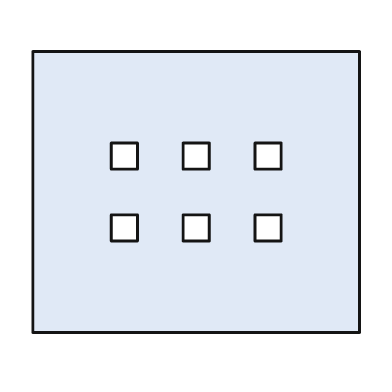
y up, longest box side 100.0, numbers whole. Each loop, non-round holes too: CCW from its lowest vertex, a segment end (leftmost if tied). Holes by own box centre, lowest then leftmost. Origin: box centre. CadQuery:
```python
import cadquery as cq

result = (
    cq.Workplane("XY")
    .moveTo(-50.0, -43.0)
    .lineTo(50.0, -43.0)
    .lineTo(50.0, 43.0)
    .lineTo(-50.0, 43.0)
    .close()
    .moveTo(-26.0, -15.0)
    .lineTo(-18.0, -15.0)
    .lineTo(-18.0, -7.0)
    .lineTo(-26.0, -7.0)
    .close()
    .moveTo(-4.0, -15.0)
    .lineTo(4.0, -15.0)
    .lineTo(4.0, -7.0)
    .lineTo(-4.0, -7.0)
    .close()
    .moveTo(18.0, -15.0)
    .lineTo(26.0, -15.0)
    .lineTo(26.0, -7.0)
    .lineTo(18.0, -7.0)
    .close()
    .moveTo(-26.0, 7.0)
    .lineTo(-18.0, 7.0)
    .lineTo(-18.0, 15.0)
    .lineTo(-26.0, 15.0)
    .close()
    .moveTo(-4.0, 7.0)
    .lineTo(4.0, 7.0)
    .lineTo(4.0, 15.0)
    .lineTo(-4.0, 15.0)
    .close()
    .moveTo(18.0, 7.0)
    .lineTo(26.0, 7.0)
    .lineTo(26.0, 15.0)
    .lineTo(18.0, 15.0)
    .close()
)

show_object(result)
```